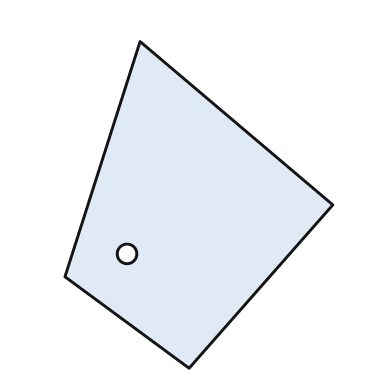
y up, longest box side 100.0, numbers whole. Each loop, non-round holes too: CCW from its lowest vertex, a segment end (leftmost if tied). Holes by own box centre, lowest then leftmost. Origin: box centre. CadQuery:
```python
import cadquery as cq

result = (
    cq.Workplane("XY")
    .moveTo(-3.0, -50.0)
    .lineTo(41.0, 0.0)
    .lineTo(-18.0, 50.0)
    .lineTo(-41.0, -22.0)
    .close()
    .moveTo(-22.0, -15.0)
    .circle(3.0)
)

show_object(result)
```